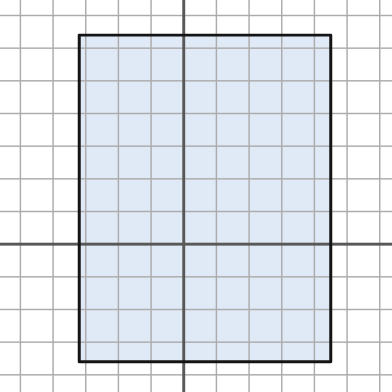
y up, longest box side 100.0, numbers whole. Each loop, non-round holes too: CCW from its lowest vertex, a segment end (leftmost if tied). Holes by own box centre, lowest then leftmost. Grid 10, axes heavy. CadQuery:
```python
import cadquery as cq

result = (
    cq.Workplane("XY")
    .moveTo(-32.0, -36.0)
    .lineTo(45.0, -36.0)
    .lineTo(45.0, 64.0)
    .lineTo(-32.0, 64.0)
    .close()
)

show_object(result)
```